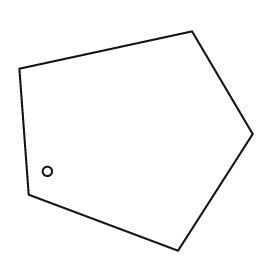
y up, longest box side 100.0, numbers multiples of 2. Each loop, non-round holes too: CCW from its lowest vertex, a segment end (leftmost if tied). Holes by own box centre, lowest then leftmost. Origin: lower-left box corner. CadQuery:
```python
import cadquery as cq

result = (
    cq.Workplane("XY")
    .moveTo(68.0, 0.0)
    .lineTo(100.0, 50.0)
    .lineTo(74.0, 94.0)
    .lineTo(0.0, 78.0)
    .lineTo(4.0, 24.0)
    .close()
    .moveTo(12.0, 34.0)
    .circle(2.0)
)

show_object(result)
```